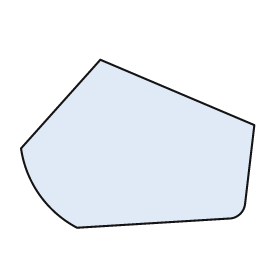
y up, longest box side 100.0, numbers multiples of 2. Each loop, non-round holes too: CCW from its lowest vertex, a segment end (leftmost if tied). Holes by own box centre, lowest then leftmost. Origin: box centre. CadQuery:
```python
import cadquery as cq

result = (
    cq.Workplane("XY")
    .moveTo(-26.0, -36.0)
    .lineTo(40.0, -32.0)
    .threePointArc((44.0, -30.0), (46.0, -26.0))
    .lineTo(50.0, 8.0)
    .lineTo(-16.0, 36.0)
    .lineTo(-50.0, -2.0)
    .threePointArc((-42.0, -22.0), (-26.0, -36.0))
    .close()
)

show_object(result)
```